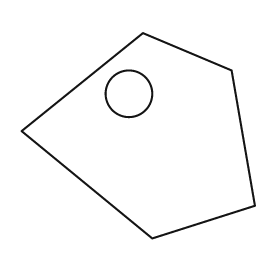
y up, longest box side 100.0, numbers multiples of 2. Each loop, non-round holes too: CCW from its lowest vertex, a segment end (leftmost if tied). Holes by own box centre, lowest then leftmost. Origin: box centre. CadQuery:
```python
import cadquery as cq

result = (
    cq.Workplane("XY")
    .moveTo(6.0, -44.0)
    .lineTo(50.0, -30.0)
    .lineTo(40.0, 28.0)
    .lineTo(2.0, 44.0)
    .lineTo(-50.0, 2.0)
    .close()
    .moveTo(-4.0, 18.0)
    .circle(10.0)
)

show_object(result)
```